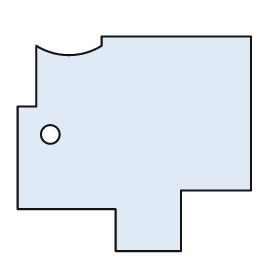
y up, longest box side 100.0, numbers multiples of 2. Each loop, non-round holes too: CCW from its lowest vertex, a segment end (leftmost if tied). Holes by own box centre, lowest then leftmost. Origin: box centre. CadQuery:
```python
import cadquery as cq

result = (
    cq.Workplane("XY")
    .moveTo(-8.0, -46.0)
    .lineTo(20.0, -46.0)
    .lineTo(20.0, -20.0)
    .lineTo(50.0, -20.0)
    .lineTo(50.0, 46.0)
    .lineTo(-14.0, 46.0)
    .lineTo(-14.0, 42.0)
    .threePointArc((-28.0, 38.0), (-42.0, 42.0))
    .lineTo(-42.0, 16.0)
    .lineTo(-50.0, 16.0)
    .lineTo(-50.0, -28.0)
    .lineTo(-8.0, -28.0)
    .close()
    .moveTo(-36.0, 4.0)
    .circle(4.0)
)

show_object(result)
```